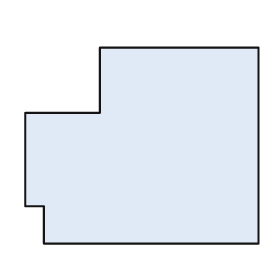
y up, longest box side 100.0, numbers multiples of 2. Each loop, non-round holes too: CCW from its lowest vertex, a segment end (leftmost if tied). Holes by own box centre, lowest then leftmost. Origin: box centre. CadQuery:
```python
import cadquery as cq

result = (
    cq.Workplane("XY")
    .moveTo(-42.0, -42.0)
    .lineTo(50.0, -42.0)
    .lineTo(50.0, 42.0)
    .lineTo(-18.0, 42.0)
    .lineTo(-18.0, 14.0)
    .lineTo(-50.0, 14.0)
    .lineTo(-50.0, -26.0)
    .lineTo(-42.0, -26.0)
    .close()
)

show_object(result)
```